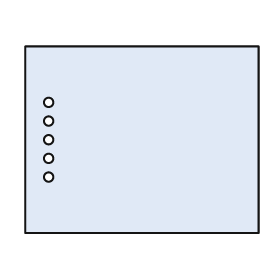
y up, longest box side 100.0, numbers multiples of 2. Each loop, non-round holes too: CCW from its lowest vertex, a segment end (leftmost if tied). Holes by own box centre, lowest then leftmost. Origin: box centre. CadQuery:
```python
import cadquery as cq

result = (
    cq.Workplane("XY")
    .moveTo(-50.0, -40.0)
    .lineTo(50.0, -40.0)
    .lineTo(50.0, 40.0)
    .lineTo(-50.0, 40.0)
    .close()
    .moveTo(-40.0, -16.0)
    .circle(2.0)
    .moveTo(-40.0, -8.0)
    .circle(2.0)
    .moveTo(-40.0, 0.0)
    .circle(2.0)
    .moveTo(-40.0, 8.0)
    .circle(2.0)
    .moveTo(-40.0, 16.0)
    .circle(2.0)
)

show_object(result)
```